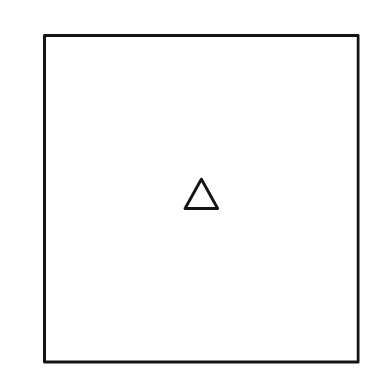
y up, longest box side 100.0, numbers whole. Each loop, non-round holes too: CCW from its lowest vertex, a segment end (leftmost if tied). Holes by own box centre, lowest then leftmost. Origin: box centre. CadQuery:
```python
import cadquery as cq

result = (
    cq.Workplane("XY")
    .moveTo(-48.0, -50.0)
    .lineTo(48.0, -50.0)
    .lineTo(48.0, 50.0)
    .lineTo(-48.0, 50.0)
    .close()
    .moveTo(-5.0, -3.0)
    .lineTo(5.0, -3.0)
    .lineTo(0.0, 6.0)
    .close()
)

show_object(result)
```